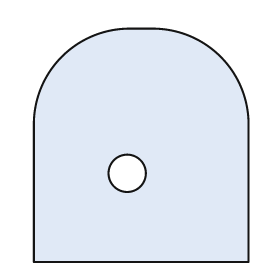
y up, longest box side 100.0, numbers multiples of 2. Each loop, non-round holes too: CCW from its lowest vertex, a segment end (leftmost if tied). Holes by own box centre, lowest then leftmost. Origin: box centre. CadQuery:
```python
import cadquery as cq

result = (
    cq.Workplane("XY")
    .moveTo(-46.0, -50.0)
    .lineTo(46.0, -50.0)
    .lineTo(46.0, 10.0)
    .threePointArc((34.0, 38.0), (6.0, 50.0))
    .lineTo(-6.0, 50.0)
    .threePointArc((-34.0, 38.0), (-46.0, 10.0))
    .close()
    .moveTo(-6.0, -12.0)
    .circle(8.0)
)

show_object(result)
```